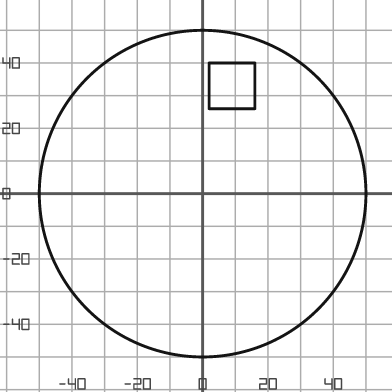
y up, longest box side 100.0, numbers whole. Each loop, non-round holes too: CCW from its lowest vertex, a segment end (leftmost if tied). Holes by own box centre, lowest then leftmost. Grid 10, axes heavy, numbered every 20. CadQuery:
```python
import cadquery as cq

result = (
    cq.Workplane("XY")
    .moveTo(0.0, 0.0)
    .circle(50.0)
    .moveTo(2.0, 26.0)
    .lineTo(16.0, 26.0)
    .lineTo(16.0, 40.0)
    .lineTo(2.0, 40.0)
    .close()
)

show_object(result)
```